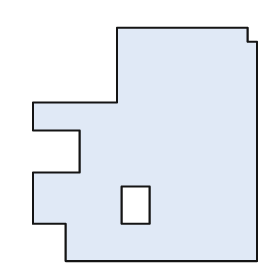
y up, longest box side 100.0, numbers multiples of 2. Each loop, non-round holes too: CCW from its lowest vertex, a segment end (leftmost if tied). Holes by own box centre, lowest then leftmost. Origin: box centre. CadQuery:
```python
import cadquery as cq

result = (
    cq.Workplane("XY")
    .moveTo(-34.0, -50.0)
    .lineTo(48.0, -50.0)
    .lineTo(48.0, 44.0)
    .lineTo(44.0, 44.0)
    .lineTo(44.0, 50.0)
    .lineTo(-12.0, 50.0)
    .lineTo(-12.0, 18.0)
    .lineTo(-48.0, 18.0)
    .lineTo(-48.0, 6.0)
    .lineTo(-28.0, 6.0)
    .lineTo(-28.0, -12.0)
    .lineTo(-48.0, -12.0)
    .lineTo(-48.0, -34.0)
    .lineTo(-34.0, -34.0)
    .close()
    .moveTo(-10.0, -34.0)
    .lineTo(2.0, -34.0)
    .lineTo(2.0, -18.0)
    .lineTo(-10.0, -18.0)
    .close()
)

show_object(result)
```